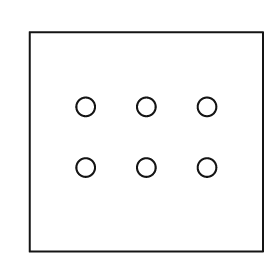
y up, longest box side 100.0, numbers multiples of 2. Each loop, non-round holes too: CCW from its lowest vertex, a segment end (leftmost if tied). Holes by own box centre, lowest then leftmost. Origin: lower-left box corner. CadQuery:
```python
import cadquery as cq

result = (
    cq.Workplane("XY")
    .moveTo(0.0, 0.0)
    .lineTo(100.0, 0.0)
    .lineTo(100.0, 94.0)
    .lineTo(0.0, 94.0)
    .close()
    .moveTo(24.0, 36.0)
    .circle(4.0)
    .moveTo(50.0, 36.0)
    .circle(4.0)
    .moveTo(76.0, 36.0)
    .circle(4.0)
    .moveTo(24.0, 62.0)
    .circle(4.0)
    .moveTo(50.0, 62.0)
    .circle(4.0)
    .moveTo(76.0, 62.0)
    .circle(4.0)
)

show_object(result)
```